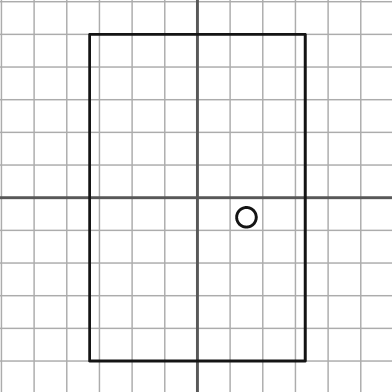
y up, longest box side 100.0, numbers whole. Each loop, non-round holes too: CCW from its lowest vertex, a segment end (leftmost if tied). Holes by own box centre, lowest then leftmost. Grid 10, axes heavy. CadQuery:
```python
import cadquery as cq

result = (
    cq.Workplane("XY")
    .moveTo(-33.0, -50.0)
    .lineTo(33.0, -50.0)
    .lineTo(33.0, 50.0)
    .lineTo(-33.0, 50.0)
    .close()
    .moveTo(15.0, -6.0)
    .circle(3.0)
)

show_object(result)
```